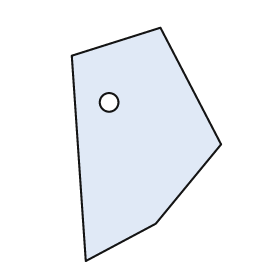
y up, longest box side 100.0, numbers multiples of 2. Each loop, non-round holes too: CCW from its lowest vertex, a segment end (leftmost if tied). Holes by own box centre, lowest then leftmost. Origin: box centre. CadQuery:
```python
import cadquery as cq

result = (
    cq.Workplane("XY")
    .moveTo(-26.0, -50.0)
    .lineTo(4.0, -34.0)
    .lineTo(32.0, 0.0)
    .lineTo(6.0, 50.0)
    .lineTo(-32.0, 38.0)
    .close()
    .moveTo(-16.0, 18.0)
    .circle(4.0)
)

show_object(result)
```